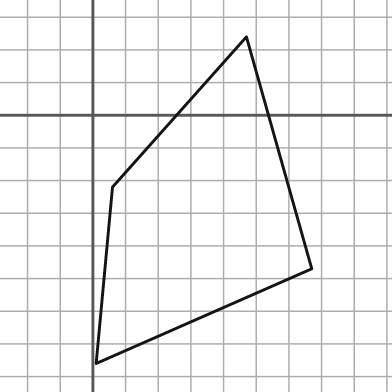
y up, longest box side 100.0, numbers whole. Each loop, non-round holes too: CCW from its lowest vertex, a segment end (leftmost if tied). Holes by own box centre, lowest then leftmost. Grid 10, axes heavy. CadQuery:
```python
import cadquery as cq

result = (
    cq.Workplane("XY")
    .moveTo(1.0, -76.0)
    .lineTo(67.0, -47.0)
    .lineTo(47.0, 24.0)
    .lineTo(6.0, -22.0)
    .close()
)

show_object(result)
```